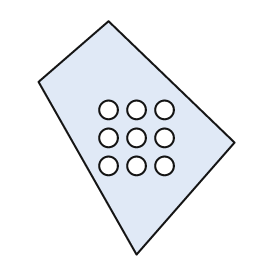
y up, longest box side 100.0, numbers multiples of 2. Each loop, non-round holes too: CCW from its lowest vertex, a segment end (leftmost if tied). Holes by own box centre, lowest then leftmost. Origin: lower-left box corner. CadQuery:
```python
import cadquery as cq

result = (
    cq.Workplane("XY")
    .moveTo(42.0, 0.0)
    .lineTo(84.0, 48.0)
    .lineTo(30.0, 100.0)
    .lineTo(0.0, 74.0)
    .close()
    .moveTo(30.0, 38.0)
    .circle(4.0)
    .moveTo(42.0, 38.0)
    .circle(4.0)
    .moveTo(54.0, 38.0)
    .circle(4.0)
    .moveTo(30.0, 50.0)
    .circle(4.0)
    .moveTo(42.0, 50.0)
    .circle(4.0)
    .moveTo(54.0, 50.0)
    .circle(4.0)
    .moveTo(30.0, 62.0)
    .circle(4.0)
    .moveTo(42.0, 62.0)
    .circle(4.0)
    .moveTo(54.0, 62.0)
    .circle(4.0)
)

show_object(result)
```